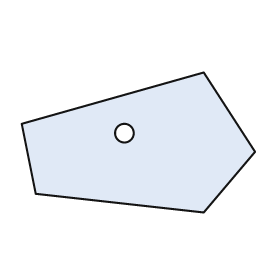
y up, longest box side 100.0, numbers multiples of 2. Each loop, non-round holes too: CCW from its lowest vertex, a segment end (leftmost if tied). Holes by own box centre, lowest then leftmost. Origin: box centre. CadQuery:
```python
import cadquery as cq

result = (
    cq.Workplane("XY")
    .moveTo(28.0, -30.0)
    .lineTo(50.0, -4.0)
    .lineTo(28.0, 30.0)
    .lineTo(-50.0, 8.0)
    .lineTo(-44.0, -22.0)
    .close()
    .moveTo(-6.0, 4.0)
    .circle(4.0)
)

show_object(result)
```